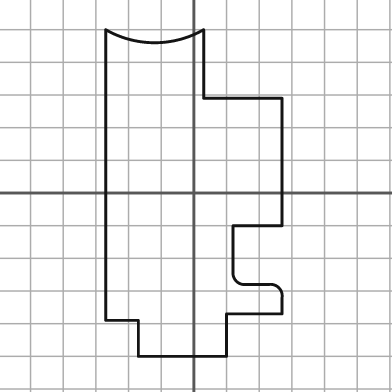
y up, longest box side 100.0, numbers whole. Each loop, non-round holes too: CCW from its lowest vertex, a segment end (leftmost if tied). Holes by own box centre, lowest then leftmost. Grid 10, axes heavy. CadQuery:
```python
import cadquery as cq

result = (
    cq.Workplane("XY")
    .moveTo(-17.0, -50.0)
    .lineTo(10.0, -50.0)
    .lineTo(10.0, -37.0)
    .lineTo(27.0, -37.0)
    .lineTo(27.0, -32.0)
    .threePointArc((26.0, -29.0), (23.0, -28.0))
    .lineTo(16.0, -28.0)
    .threePointArc((13.0, -27.0), (12.0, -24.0))
    .lineTo(12.0, -10.0)
    .lineTo(27.0, -10.0)
    .lineTo(27.0, 29.0)
    .lineTo(3.0, 29.0)
    .lineTo(3.0, 50.0)
    .threePointArc((-12.0, 46.0), (-27.0, 50.0))
    .lineTo(-27.0, -39.0)
    .lineTo(-17.0, -39.0)
    .close()
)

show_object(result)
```